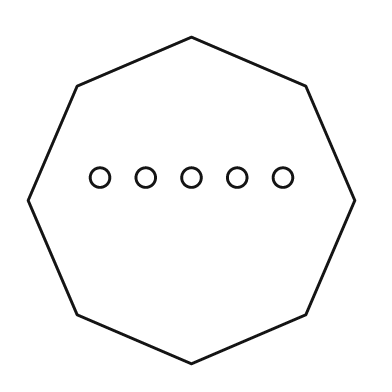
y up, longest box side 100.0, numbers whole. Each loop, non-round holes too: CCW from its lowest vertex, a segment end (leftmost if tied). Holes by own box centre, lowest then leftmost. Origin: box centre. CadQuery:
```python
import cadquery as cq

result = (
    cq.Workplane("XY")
    .moveTo(0.0, -50.0)
    .lineTo(35.0, -35.0)
    .lineTo(50.0, 0.0)
    .lineTo(35.0, 35.0)
    .lineTo(0.0, 50.0)
    .lineTo(-35.0, 35.0)
    .lineTo(-50.0, 0.0)
    .lineTo(-35.0, -35.0)
    .close()
    .moveTo(-28.0, 7.0)
    .circle(3.0)
    .moveTo(-14.0, 7.0)
    .circle(3.0)
    .moveTo(0.0, 7.0)
    .circle(3.0)
    .moveTo(14.0, 7.0)
    .circle(3.0)
    .moveTo(28.0, 7.0)
    .circle(3.0)
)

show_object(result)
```